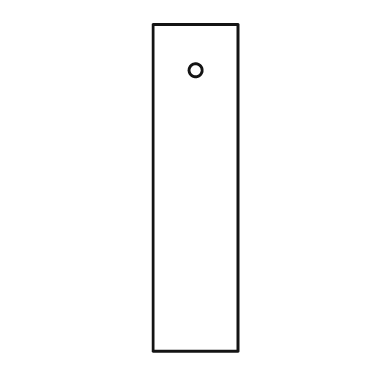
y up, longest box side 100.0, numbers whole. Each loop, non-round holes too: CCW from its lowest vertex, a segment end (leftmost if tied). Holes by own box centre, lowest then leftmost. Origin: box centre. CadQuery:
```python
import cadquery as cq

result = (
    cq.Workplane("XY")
    .moveTo(-13.0, -50.0)
    .lineTo(13.0, -50.0)
    .lineTo(13.0, 50.0)
    .lineTo(-13.0, 50.0)
    .close()
    .moveTo(0.0, 36.0)
    .circle(2.0)
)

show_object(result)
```